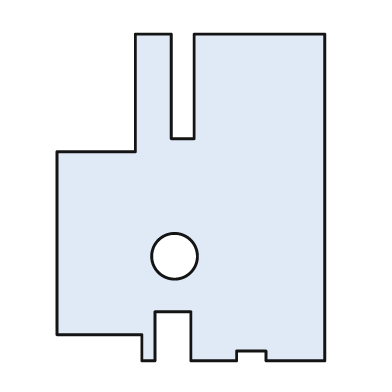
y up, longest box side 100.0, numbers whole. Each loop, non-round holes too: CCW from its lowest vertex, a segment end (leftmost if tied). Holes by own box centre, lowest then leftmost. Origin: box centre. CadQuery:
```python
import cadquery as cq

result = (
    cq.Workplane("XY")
    .moveTo(-15.0, -50.0)
    .lineTo(-11.0, -50.0)
    .lineTo(-11.0, -35.0)
    .lineTo(0.0, -35.0)
    .lineTo(0.0, -50.0)
    .lineTo(14.0, -50.0)
    .lineTo(14.0, -47.0)
    .lineTo(23.0, -47.0)
    .lineTo(23.0, -50.0)
    .lineTo(41.0, -50.0)
    .lineTo(41.0, 50.0)
    .lineTo(1.0, 50.0)
    .lineTo(1.0, 18.0)
    .lineTo(-6.0, 18.0)
    .lineTo(-6.0, 50.0)
    .lineTo(-17.0, 50.0)
    .lineTo(-17.0, 14.0)
    .lineTo(-41.0, 14.0)
    .lineTo(-41.0, -42.0)
    .lineTo(-15.0, -42.0)
    .close()
    .moveTo(-5.0, -18.0)
    .circle(7.0)
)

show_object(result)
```